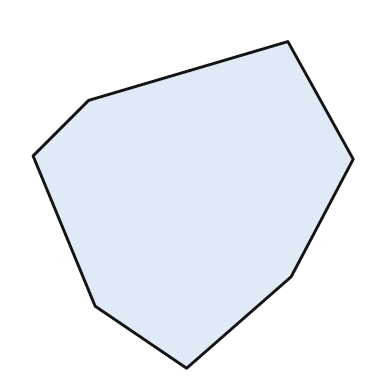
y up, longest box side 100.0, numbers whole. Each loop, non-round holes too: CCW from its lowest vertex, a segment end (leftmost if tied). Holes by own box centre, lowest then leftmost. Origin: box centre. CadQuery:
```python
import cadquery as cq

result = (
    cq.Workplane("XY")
    .moveTo(-2.0, -50.0)
    .lineTo(30.0, -22.0)
    .lineTo(49.0, 14.0)
    .lineTo(29.0, 50.0)
    .lineTo(-32.0, 32.0)
    .lineTo(-49.0, 15.0)
    .lineTo(-30.0, -31.0)
    .close()
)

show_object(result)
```